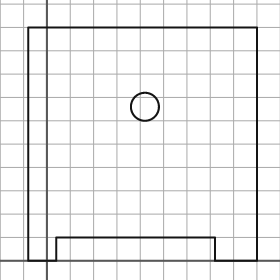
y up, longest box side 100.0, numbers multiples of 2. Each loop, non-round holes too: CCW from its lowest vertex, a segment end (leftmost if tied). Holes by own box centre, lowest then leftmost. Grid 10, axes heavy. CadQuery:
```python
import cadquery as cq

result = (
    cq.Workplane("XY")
    .moveTo(-8.0, 0.0)
    .lineTo(4.0, 0.0)
    .lineTo(4.0, 10.0)
    .lineTo(72.0, 10.0)
    .lineTo(72.0, 0.0)
    .lineTo(90.0, 0.0)
    .lineTo(90.0, 100.0)
    .lineTo(-8.0, 100.0)
    .close()
    .moveTo(42.0, 66.0)
    .circle(6.0)
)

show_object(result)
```